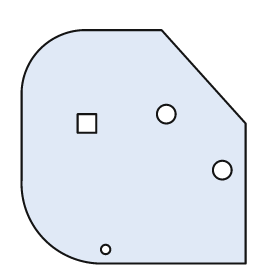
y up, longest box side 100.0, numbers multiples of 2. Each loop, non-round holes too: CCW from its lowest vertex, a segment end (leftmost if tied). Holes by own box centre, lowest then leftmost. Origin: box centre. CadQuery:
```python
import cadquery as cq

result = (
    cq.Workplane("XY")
    .moveTo(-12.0, -50.0)
    .lineTo(48.0, -50.0)
    .lineTo(48.0, 10.0)
    .lineTo(12.0, 50.0)
    .lineTo(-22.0, 50.0)
    .threePointArc((-40.0, 42.0), (-48.0, 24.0))
    .lineTo(-48.0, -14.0)
    .threePointArc((-38.0, -40.0), (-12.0, -50.0))
    .close()
    .moveTo(-12.0, -44.0)
    .circle(2.0)
    .moveTo(38.0, -10.0)
    .circle(4.0)
    .moveTo(-24.0, 6.0)
    .lineTo(-16.0, 6.0)
    .lineTo(-16.0, 14.0)
    .lineTo(-24.0, 14.0)
    .close()
    .moveTo(14.0, 14.0)
    .circle(4.0)
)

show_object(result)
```